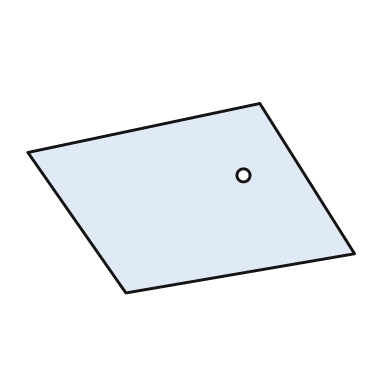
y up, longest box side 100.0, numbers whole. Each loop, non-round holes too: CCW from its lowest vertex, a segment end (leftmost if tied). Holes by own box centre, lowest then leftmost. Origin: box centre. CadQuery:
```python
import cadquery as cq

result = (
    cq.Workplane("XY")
    .moveTo(-20.0, -29.0)
    .lineTo(50.0, -17.0)
    .lineTo(21.0, 29.0)
    .lineTo(-50.0, 14.0)
    .close()
    .moveTo(16.0, 7.0)
    .circle(2.0)
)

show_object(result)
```